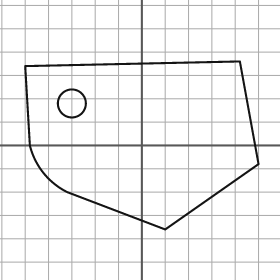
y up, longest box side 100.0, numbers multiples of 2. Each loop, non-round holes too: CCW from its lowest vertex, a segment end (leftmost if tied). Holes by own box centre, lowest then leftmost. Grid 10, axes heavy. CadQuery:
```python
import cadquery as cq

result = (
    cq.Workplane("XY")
    .moveTo(10.0, -36.0)
    .lineTo(50.0, -8.0)
    .lineTo(42.0, 36.0)
    .lineTo(-50.0, 34.0)
    .lineTo(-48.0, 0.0)
    .threePointArc((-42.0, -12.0), (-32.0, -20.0))
    .close()
    .moveTo(-30.0, 18.0)
    .circle(6.0)
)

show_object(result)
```